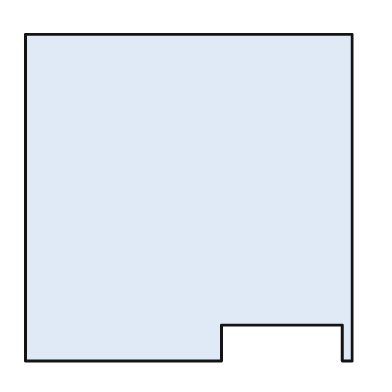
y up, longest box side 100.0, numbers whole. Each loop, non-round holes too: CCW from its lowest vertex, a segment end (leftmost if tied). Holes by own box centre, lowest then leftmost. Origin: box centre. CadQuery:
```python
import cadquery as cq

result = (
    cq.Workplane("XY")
    .moveTo(-50.0, -50.0)
    .lineTo(10.0, -50.0)
    .lineTo(10.0, -39.0)
    .lineTo(47.0, -39.0)
    .lineTo(47.0, -50.0)
    .lineTo(50.0, -50.0)
    .lineTo(50.0, 50.0)
    .lineTo(-50.0, 50.0)
    .close()
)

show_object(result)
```